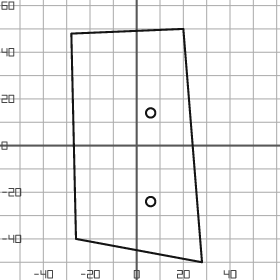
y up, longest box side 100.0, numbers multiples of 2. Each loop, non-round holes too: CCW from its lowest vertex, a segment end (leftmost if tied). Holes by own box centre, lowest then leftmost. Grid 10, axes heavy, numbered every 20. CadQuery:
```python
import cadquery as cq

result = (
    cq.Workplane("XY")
    .moveTo(28.0, -50.0)
    .lineTo(20.0, 50.0)
    .lineTo(-28.0, 48.0)
    .lineTo(-26.0, -40.0)
    .close()
    .moveTo(6.0, -24.0)
    .circle(2.0)
    .moveTo(6.0, 14.0)
    .circle(2.0)
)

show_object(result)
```